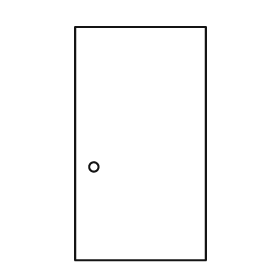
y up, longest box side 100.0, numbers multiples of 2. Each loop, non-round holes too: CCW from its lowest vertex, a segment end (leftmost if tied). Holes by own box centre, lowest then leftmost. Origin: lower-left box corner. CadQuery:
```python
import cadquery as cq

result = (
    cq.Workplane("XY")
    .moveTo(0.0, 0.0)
    .lineTo(56.0, 0.0)
    .lineTo(56.0, 100.0)
    .lineTo(0.0, 100.0)
    .close()
    .moveTo(8.0, 40.0)
    .circle(2.0)
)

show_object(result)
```